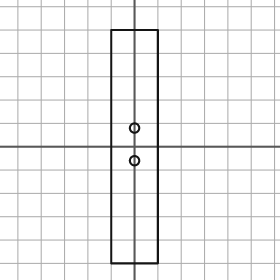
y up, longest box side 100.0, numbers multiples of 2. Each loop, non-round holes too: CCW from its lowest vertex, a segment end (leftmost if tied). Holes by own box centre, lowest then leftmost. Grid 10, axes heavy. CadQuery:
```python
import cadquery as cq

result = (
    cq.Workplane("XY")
    .moveTo(-10.0, -50.0)
    .lineTo(10.0, -50.0)
    .lineTo(10.0, 50.0)
    .lineTo(-10.0, 50.0)
    .close()
    .moveTo(0.0, -6.0)
    .circle(2.0)
    .moveTo(0.0, 8.0)
    .circle(2.0)
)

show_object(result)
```